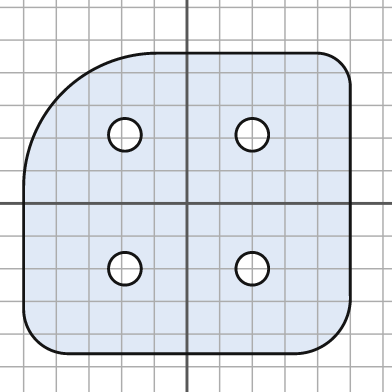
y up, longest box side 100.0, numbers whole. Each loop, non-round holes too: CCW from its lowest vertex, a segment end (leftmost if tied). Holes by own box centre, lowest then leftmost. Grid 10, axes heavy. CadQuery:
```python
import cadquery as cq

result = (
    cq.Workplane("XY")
    .moveTo(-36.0, -46.0)
    .lineTo(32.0, -46.0)
    .threePointArc((45.0, -41.0), (50.0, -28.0))
    .lineTo(50.0, 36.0)
    .threePointArc((47.0, 43.0), (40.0, 46.0))
    .lineTo(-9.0, 46.0)
    .threePointArc((-38.0, 34.0), (-50.0, 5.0))
    .lineTo(-50.0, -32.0)
    .threePointArc((-46.0, -42.0), (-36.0, -46.0))
    .close()
    .moveTo(-19.0, -20.0)
    .circle(5.0)
    .moveTo(20.0, -20.0)
    .circle(5.0)
    .moveTo(-19.0, 21.0)
    .circle(5.0)
    .moveTo(20.0, 21.0)
    .circle(5.0)
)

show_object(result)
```